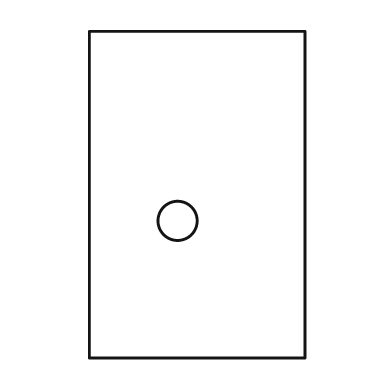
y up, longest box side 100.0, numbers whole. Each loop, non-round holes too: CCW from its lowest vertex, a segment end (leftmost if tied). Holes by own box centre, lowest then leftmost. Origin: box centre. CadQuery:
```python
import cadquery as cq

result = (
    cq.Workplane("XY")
    .moveTo(-33.0, -50.0)
    .lineTo(33.0, -50.0)
    .lineTo(33.0, 50.0)
    .lineTo(-33.0, 50.0)
    .close()
    .moveTo(-6.0, -8.0)
    .circle(6.0)
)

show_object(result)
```